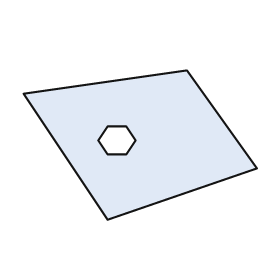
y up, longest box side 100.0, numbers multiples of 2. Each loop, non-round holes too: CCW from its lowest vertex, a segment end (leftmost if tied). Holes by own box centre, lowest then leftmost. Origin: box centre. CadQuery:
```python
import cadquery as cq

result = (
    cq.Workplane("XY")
    .moveTo(-14.0, -32.0)
    .lineTo(50.0, -10.0)
    .lineTo(20.0, 32.0)
    .lineTo(-50.0, 22.0)
    .close()
    .moveTo(-14.0, -4.0)
    .lineTo(-6.0, -4.0)
    .lineTo(-2.0, 2.0)
    .lineTo(-6.0, 8.0)
    .lineTo(-14.0, 8.0)
    .lineTo(-18.0, 2.0)
    .close()
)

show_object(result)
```